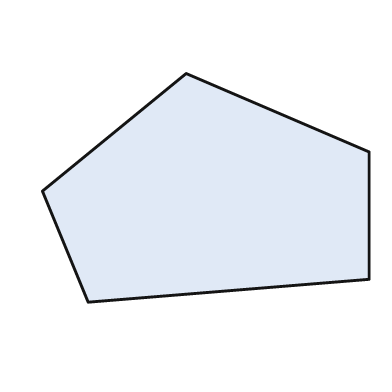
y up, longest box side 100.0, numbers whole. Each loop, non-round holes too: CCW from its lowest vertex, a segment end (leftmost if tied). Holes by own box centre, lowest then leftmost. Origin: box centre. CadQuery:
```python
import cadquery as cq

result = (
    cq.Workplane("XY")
    .moveTo(-36.0, -35.0)
    .lineTo(50.0, -28.0)
    .lineTo(50.0, 11.0)
    .lineTo(-6.0, 35.0)
    .lineTo(-50.0, -1.0)
    .close()
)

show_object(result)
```